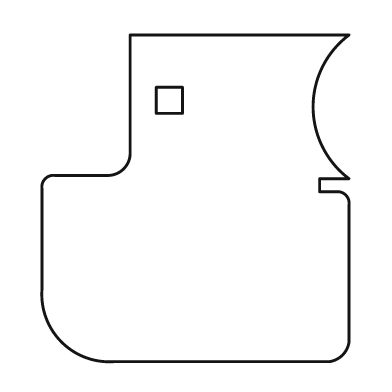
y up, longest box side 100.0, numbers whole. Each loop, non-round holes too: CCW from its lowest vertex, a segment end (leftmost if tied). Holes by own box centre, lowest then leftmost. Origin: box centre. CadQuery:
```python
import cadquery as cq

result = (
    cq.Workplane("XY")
    .moveTo(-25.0, -50.0)
    .lineTo(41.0, -50.0)
    .threePointArc((45.0, -48.0), (47.0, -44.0))
    .lineTo(47.0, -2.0)
    .threePointArc((46.0, 1.0), (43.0, 2.0))
    .lineTo(38.0, 2.0)
    .lineTo(38.0, 6.0)
    .lineTo(47.0, 6.0)
    .threePointArc((36.0, 28.0), (47.0, 50.0))
    .lineTo(-20.0, 50.0)
    .lineTo(-20.0, 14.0)
    .threePointArc((-22.0, 9.0), (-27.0, 7.0))
    .lineTo(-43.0, 7.0)
    .threePointArc((-46.0, 6.0), (-47.0, 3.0))
    .lineTo(-47.0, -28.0)
    .threePointArc((-41.0, -44.0), (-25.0, -50.0))
    .close()
    .moveTo(-12.0, 26.0)
    .lineTo(-4.0, 26.0)
    .lineTo(-4.0, 34.0)
    .lineTo(-12.0, 34.0)
    .close()
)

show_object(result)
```